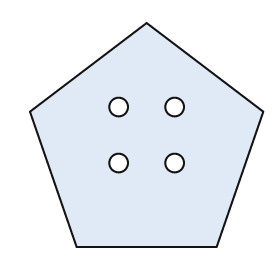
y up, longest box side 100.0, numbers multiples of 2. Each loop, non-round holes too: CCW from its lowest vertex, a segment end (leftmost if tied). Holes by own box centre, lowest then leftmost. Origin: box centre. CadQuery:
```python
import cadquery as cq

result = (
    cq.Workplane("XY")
    .moveTo(-30.0, -48.0)
    .lineTo(30.0, -48.0)
    .lineTo(50.0, 10.0)
    .lineTo(0.0, 48.0)
    .lineTo(-50.0, 10.0)
    .close()
    .moveTo(-12.0, -12.0)
    .circle(4.0)
    .moveTo(12.0, -12.0)
    .circle(4.0)
    .moveTo(-12.0, 12.0)
    .circle(4.0)
    .moveTo(12.0, 12.0)
    .circle(4.0)
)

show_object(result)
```